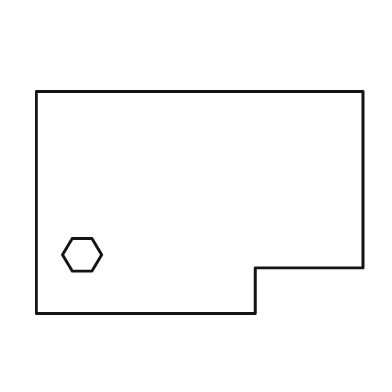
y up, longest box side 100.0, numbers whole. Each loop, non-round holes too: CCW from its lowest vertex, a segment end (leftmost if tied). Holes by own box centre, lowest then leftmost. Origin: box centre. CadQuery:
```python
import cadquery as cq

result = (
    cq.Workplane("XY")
    .moveTo(-50.0, -34.0)
    .lineTo(17.0, -34.0)
    .lineTo(17.0, -20.0)
    .lineTo(50.0, -20.0)
    .lineTo(50.0, 34.0)
    .lineTo(-50.0, 34.0)
    .close()
    .moveTo(-39.0, -21.0)
    .lineTo(-33.0, -21.0)
    .lineTo(-30.0, -16.0)
    .lineTo(-33.0, -11.0)
    .lineTo(-39.0, -11.0)
    .lineTo(-42.0, -16.0)
    .close()
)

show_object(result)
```